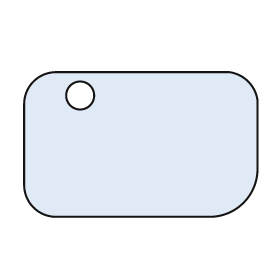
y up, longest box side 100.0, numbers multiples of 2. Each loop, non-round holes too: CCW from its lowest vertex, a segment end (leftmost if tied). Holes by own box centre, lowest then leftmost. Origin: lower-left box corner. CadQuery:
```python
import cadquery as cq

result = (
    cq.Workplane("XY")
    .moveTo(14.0, 0.0)
    .lineTo(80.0, 0.0)
    .threePointArc((94.0, 6.0), (100.0, 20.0))
    .lineTo(100.0, 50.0)
    .threePointArc((96.0, 58.0), (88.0, 62.0))
    .lineTo(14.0, 62.0)
    .threePointArc((4.0, 58.0), (0.0, 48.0))
    .lineTo(0.0, 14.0)
    .threePointArc((4.0, 4.0), (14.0, 0.0))
    .close()
    .moveTo(24.0, 52.0)
    .circle(6.0)
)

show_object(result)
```